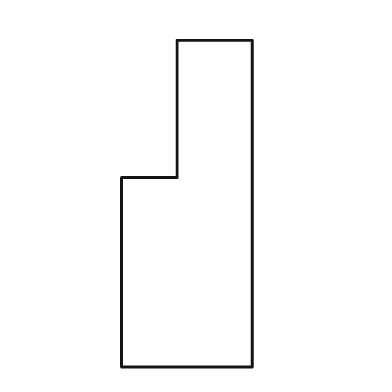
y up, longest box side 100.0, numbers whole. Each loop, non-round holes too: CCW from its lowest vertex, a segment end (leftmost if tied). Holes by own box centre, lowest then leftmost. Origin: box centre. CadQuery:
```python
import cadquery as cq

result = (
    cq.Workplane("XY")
    .moveTo(-20.0, -50.0)
    .lineTo(20.0, -50.0)
    .lineTo(20.0, 50.0)
    .lineTo(-3.0, 50.0)
    .lineTo(-3.0, 8.0)
    .lineTo(-20.0, 8.0)
    .close()
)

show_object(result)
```